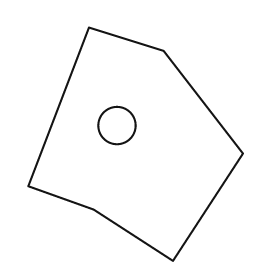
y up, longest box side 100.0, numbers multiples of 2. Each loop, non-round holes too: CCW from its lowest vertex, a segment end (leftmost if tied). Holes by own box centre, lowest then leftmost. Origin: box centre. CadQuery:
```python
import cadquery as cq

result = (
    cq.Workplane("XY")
    .moveTo(16.0, -50.0)
    .lineTo(46.0, -4.0)
    .lineTo(12.0, 40.0)
    .lineTo(-20.0, 50.0)
    .lineTo(-46.0, -18.0)
    .lineTo(-18.0, -28.0)
    .close()
    .moveTo(-8.0, 8.0)
    .circle(8.0)
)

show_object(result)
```